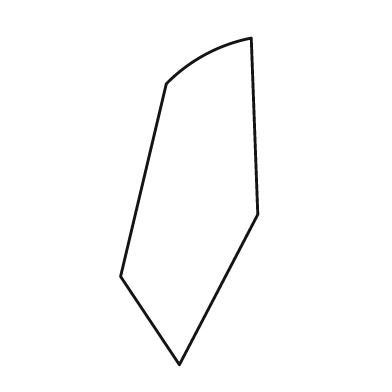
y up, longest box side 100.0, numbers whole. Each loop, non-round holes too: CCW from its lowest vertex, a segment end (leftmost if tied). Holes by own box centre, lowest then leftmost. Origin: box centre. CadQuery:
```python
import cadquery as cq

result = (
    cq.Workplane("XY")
    .moveTo(-3.0, -50.0)
    .lineTo(21.0, -4.0)
    .lineTo(19.0, 50.0)
    .threePointArc((5.0, 45.0), (-7.0, 36.0))
    .lineTo(-21.0, -23.0)
    .close()
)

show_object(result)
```